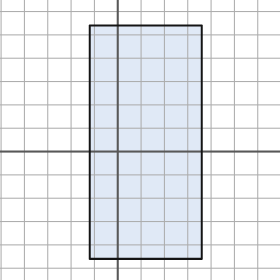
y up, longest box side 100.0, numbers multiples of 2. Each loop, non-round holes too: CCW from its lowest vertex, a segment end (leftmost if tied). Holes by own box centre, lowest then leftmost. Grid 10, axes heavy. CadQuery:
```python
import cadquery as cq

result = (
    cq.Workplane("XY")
    .moveTo(-12.0, -46.0)
    .lineTo(36.0, -46.0)
    .lineTo(36.0, 54.0)
    .lineTo(-12.0, 54.0)
    .close()
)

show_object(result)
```